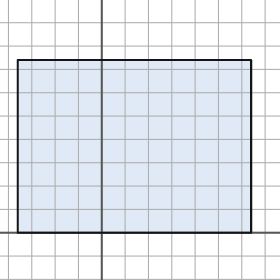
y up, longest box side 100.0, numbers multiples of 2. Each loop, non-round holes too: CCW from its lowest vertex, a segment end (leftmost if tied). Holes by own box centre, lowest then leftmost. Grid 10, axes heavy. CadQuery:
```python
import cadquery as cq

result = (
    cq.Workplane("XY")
    .moveTo(-36.0, 0.0)
    .lineTo(64.0, 0.0)
    .lineTo(64.0, 74.0)
    .lineTo(-36.0, 74.0)
    .close()
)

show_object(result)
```